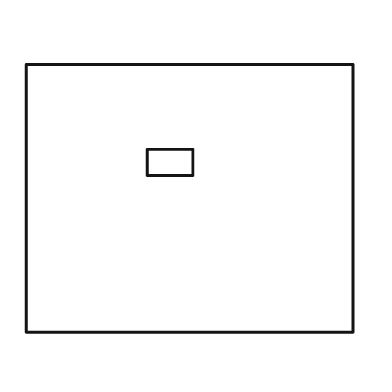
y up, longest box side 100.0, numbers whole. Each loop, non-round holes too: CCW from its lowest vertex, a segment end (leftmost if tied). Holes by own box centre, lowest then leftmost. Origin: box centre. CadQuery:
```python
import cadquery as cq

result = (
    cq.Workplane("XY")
    .moveTo(-50.0, -41.0)
    .lineTo(50.0, -41.0)
    .lineTo(50.0, 41.0)
    .lineTo(-50.0, 41.0)
    .close()
    .moveTo(-13.0, 7.0)
    .lineTo(1.0, 7.0)
    .lineTo(1.0, 15.0)
    .lineTo(-13.0, 15.0)
    .close()
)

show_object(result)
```